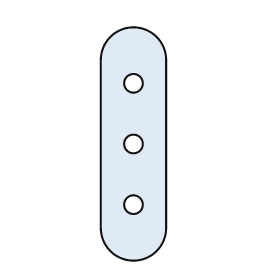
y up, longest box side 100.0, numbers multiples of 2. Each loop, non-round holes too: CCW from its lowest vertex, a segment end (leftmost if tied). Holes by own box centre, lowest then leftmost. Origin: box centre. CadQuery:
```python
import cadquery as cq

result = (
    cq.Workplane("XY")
    .moveTo(-14.0, -36.0)
    .threePointArc((0.0, -50.0), (14.0, -36.0))
    .lineTo(14.0, 36.0)
    .threePointArc((0.0, 50.0), (-14.0, 36.0))
    .close()
    .moveTo(0.0, -26.0)
    .circle(4.0)
    .moveTo(0.0, 0.0)
    .circle(4.0)
    .moveTo(0.0, 26.0)
    .circle(4.0)
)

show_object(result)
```